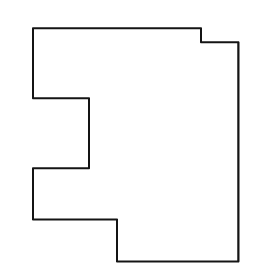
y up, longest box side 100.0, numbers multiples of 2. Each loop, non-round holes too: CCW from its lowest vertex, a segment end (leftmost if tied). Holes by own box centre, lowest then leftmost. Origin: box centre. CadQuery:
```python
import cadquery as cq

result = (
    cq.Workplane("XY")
    .moveTo(-8.0, -50.0)
    .lineTo(44.0, -50.0)
    .lineTo(44.0, 44.0)
    .lineTo(28.0, 44.0)
    .lineTo(28.0, 50.0)
    .lineTo(-44.0, 50.0)
    .lineTo(-44.0, 20.0)
    .lineTo(-20.0, 20.0)
    .lineTo(-20.0, -10.0)
    .lineTo(-44.0, -10.0)
    .lineTo(-44.0, -32.0)
    .lineTo(-8.0, -32.0)
    .close()
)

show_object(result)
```